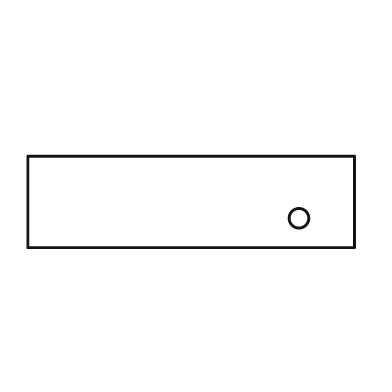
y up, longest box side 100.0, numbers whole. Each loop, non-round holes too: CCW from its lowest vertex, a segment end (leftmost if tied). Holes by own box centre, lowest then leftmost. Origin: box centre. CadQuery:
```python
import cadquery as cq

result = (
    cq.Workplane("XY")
    .moveTo(-50.0, -14.0)
    .lineTo(50.0, -14.0)
    .lineTo(50.0, 14.0)
    .lineTo(-50.0, 14.0)
    .close()
    .moveTo(33.0, -5.0)
    .circle(3.0)
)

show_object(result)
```